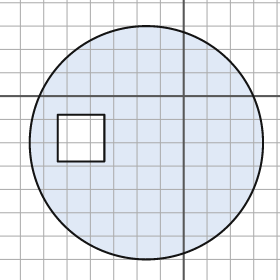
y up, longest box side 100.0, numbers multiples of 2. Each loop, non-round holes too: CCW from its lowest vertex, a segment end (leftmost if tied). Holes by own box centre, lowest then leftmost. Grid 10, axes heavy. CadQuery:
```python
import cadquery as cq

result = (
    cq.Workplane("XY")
    .moveTo(-16.0, -20.0)
    .circle(50.0)
    .moveTo(-54.0, -28.0)
    .lineTo(-34.0, -28.0)
    .lineTo(-34.0, -8.0)
    .lineTo(-54.0, -8.0)
    .close()
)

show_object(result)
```